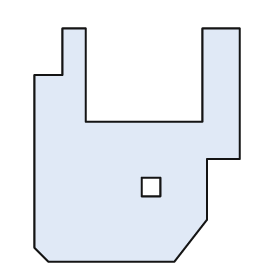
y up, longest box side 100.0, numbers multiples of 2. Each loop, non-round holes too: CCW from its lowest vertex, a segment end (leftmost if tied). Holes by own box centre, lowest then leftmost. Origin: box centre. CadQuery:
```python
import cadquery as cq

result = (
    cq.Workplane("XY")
    .moveTo(-38.0, -50.0)
    .lineTo(16.0, -50.0)
    .lineTo(30.0, -32.0)
    .lineTo(30.0, -6.0)
    .lineTo(44.0, -6.0)
    .lineTo(44.0, 50.0)
    .lineTo(28.0, 50.0)
    .lineTo(28.0, 10.0)
    .lineTo(-22.0, 10.0)
    .lineTo(-22.0, 50.0)
    .lineTo(-32.0, 50.0)
    .lineTo(-32.0, 30.0)
    .lineTo(-44.0, 30.0)
    .lineTo(-44.0, -44.0)
    .close()
    .moveTo(2.0, -22.0)
    .lineTo(10.0, -22.0)
    .lineTo(10.0, -14.0)
    .lineTo(2.0, -14.0)
    .close()
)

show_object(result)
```